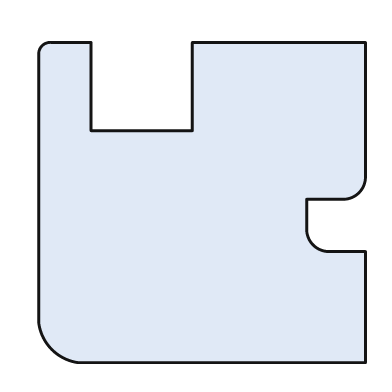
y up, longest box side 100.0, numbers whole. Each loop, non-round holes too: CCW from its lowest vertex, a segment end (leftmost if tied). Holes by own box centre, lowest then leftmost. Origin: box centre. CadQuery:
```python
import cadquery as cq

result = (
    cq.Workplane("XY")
    .moveTo(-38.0, -49.0)
    .lineTo(50.0, -49.0)
    .lineTo(50.0, -15.0)
    .lineTo(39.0, -15.0)
    .threePointArc((34.0, -13.0), (32.0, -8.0))
    .lineTo(32.0, 1.0)
    .lineTo(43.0, 1.0)
    .threePointArc((48.0, 3.0), (50.0, 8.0))
    .lineTo(50.0, 49.0)
    .lineTo(-3.0, 49.0)
    .lineTo(-3.0, 22.0)
    .lineTo(-34.0, 22.0)
    .lineTo(-34.0, 49.0)
    .lineTo(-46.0, 49.0)
    .threePointArc((-49.0, 48.0), (-50.0, 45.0))
    .lineTo(-50.0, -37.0)
    .threePointArc((-46.0, -45.0), (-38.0, -49.0))
    .close()
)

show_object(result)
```